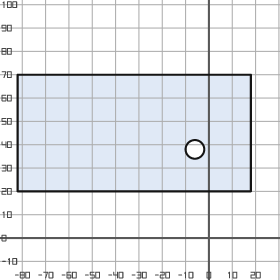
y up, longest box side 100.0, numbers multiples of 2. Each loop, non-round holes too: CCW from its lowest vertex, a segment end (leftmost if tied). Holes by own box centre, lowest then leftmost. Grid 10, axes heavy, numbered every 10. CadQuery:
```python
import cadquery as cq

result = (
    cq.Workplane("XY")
    .moveTo(-82.0, 20.0)
    .lineTo(18.0, 20.0)
    .lineTo(18.0, 70.0)
    .lineTo(-82.0, 70.0)
    .close()
    .moveTo(-6.0, 38.0)
    .circle(4.0)
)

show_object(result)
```